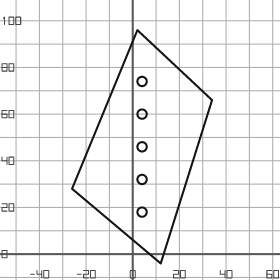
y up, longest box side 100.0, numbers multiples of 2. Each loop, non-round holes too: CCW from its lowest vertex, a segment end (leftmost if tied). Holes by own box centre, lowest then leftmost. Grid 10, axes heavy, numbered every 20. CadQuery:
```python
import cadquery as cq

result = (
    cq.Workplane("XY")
    .moveTo(12.0, -4.0)
    .lineTo(34.0, 66.0)
    .lineTo(2.0, 96.0)
    .lineTo(-26.0, 28.0)
    .close()
    .moveTo(4.0, 18.0)
    .circle(2.0)
    .moveTo(4.0, 32.0)
    .circle(2.0)
    .moveTo(4.0, 46.0)
    .circle(2.0)
    .moveTo(4.0, 60.0)
    .circle(2.0)
    .moveTo(4.0, 74.0)
    .circle(2.0)
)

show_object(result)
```